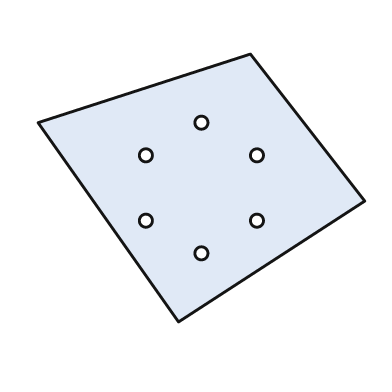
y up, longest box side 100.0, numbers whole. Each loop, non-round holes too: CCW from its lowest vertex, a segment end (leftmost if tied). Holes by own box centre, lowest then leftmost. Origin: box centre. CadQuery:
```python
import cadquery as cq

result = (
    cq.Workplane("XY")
    .moveTo(-7.0, -41.0)
    .lineTo(50.0, -4.0)
    .lineTo(15.0, 41.0)
    .lineTo(-50.0, 20.0)
    .close()
    .moveTo(0.0, -20.0)
    .circle(2.0)
    .moveTo(-17.0, -10.0)
    .circle(2.0)
    .moveTo(17.0, -10.0)
    .circle(2.0)
    .moveTo(-17.0, 10.0)
    .circle(2.0)
    .moveTo(17.0, 10.0)
    .circle(2.0)
    .moveTo(0.0, 20.0)
    .circle(2.0)
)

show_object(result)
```